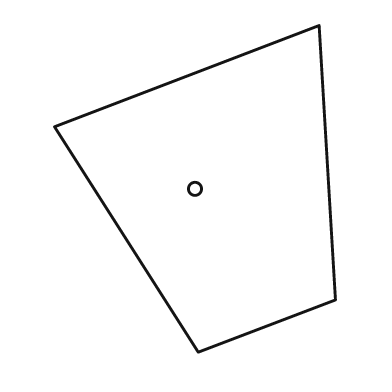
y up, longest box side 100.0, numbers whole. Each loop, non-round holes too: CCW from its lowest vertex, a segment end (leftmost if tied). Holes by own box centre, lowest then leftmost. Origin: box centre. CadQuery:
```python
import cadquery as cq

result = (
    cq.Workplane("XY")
    .moveTo(1.0, -50.0)
    .lineTo(43.0, -34.0)
    .lineTo(38.0, 50.0)
    .lineTo(-43.0, 19.0)
    .close()
    .moveTo(0.0, 0.0)
    .circle(2.0)
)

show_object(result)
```